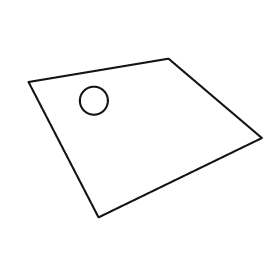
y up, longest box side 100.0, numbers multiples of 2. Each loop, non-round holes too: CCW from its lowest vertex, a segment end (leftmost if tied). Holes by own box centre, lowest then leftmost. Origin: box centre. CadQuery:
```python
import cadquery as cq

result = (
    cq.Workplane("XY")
    .moveTo(-20.0, -34.0)
    .lineTo(50.0, 0.0)
    .lineTo(10.0, 34.0)
    .lineTo(-50.0, 24.0)
    .close()
    .moveTo(-22.0, 16.0)
    .circle(6.0)
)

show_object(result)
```